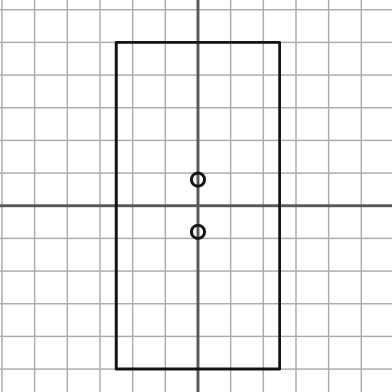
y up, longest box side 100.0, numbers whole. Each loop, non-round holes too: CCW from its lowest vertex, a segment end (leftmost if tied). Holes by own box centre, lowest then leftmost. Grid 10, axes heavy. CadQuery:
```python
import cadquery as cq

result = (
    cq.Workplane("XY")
    .moveTo(-25.0, -50.0)
    .lineTo(25.0, -50.0)
    .lineTo(25.0, 50.0)
    .lineTo(-25.0, 50.0)
    .close()
    .moveTo(0.0, -8.0)
    .circle(2.0)
    .moveTo(0.0, 8.0)
    .circle(2.0)
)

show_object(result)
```